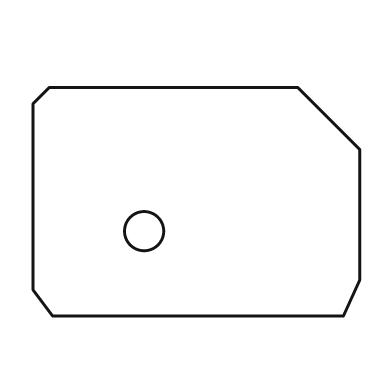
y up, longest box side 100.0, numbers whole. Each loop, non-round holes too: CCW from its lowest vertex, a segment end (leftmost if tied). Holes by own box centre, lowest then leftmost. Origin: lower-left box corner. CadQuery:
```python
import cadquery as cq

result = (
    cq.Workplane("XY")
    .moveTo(6.0, 0.0)
    .lineTo(95.0, 0.0)
    .lineTo(100.0, 11.0)
    .lineTo(100.0, 51.0)
    .lineTo(81.0, 70.0)
    .lineTo(5.0, 70.0)
    .lineTo(0.0, 65.0)
    .lineTo(0.0, 8.0)
    .close()
    .moveTo(34.0, 26.0)
    .circle(6.0)
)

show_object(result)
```